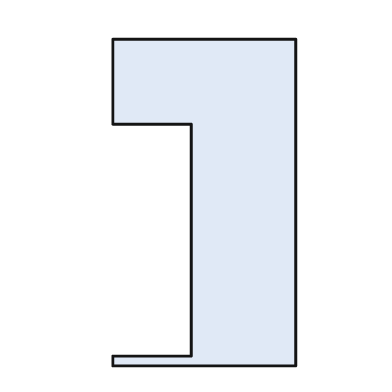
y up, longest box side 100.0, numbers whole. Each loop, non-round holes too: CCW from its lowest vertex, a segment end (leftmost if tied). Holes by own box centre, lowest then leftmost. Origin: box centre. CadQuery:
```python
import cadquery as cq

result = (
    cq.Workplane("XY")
    .moveTo(-28.0, -50.0)
    .lineTo(28.0, -50.0)
    .lineTo(28.0, 50.0)
    .lineTo(-28.0, 50.0)
    .lineTo(-28.0, 24.0)
    .lineTo(-4.0, 24.0)
    .lineTo(-4.0, -47.0)
    .lineTo(-28.0, -47.0)
    .close()
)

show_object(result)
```